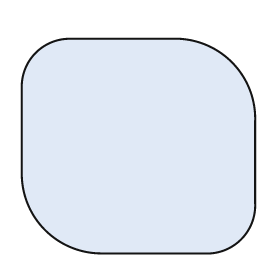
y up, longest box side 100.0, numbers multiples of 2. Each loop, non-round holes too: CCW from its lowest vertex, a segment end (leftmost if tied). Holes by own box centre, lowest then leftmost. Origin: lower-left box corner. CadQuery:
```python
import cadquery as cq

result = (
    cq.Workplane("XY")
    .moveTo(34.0, 0.0)
    .lineTo(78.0, 0.0)
    .threePointArc((94.0, 6.0), (100.0, 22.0))
    .lineTo(100.0, 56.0)
    .threePointArc((90.0, 82.0), (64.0, 92.0))
    .lineTo(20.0, 92.0)
    .threePointArc((6.0, 86.0), (0.0, 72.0))
    .lineTo(0.0, 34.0)
    .threePointArc((10.0, 10.0), (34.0, 0.0))
    .close()
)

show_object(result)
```